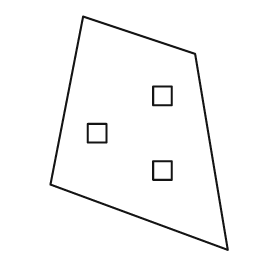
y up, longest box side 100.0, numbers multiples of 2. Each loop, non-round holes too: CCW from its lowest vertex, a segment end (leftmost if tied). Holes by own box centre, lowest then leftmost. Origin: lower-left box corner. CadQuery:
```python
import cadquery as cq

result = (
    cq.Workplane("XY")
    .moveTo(76.0, 0.0)
    .lineTo(62.0, 84.0)
    .lineTo(14.0, 100.0)
    .lineTo(0.0, 28.0)
    .close()
    .moveTo(44.0, 30.0)
    .lineTo(52.0, 30.0)
    .lineTo(52.0, 38.0)
    .lineTo(44.0, 38.0)
    .close()
    .moveTo(16.0, 46.0)
    .lineTo(24.0, 46.0)
    .lineTo(24.0, 54.0)
    .lineTo(16.0, 54.0)
    .close()
    .moveTo(44.0, 62.0)
    .lineTo(52.0, 62.0)
    .lineTo(52.0, 70.0)
    .lineTo(44.0, 70.0)
    .close()
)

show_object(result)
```